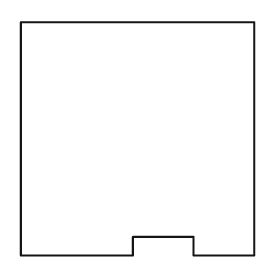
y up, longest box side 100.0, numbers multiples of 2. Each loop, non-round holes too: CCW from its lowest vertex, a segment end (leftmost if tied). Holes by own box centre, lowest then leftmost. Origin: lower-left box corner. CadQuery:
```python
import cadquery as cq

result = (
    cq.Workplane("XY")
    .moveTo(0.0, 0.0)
    .lineTo(48.0, 0.0)
    .lineTo(48.0, 8.0)
    .lineTo(74.0, 8.0)
    .lineTo(74.0, 0.0)
    .lineTo(100.0, 0.0)
    .lineTo(100.0, 100.0)
    .lineTo(0.0, 100.0)
    .close()
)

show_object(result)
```